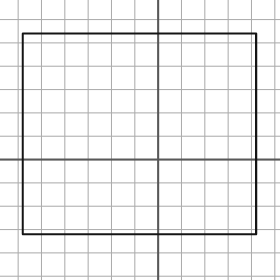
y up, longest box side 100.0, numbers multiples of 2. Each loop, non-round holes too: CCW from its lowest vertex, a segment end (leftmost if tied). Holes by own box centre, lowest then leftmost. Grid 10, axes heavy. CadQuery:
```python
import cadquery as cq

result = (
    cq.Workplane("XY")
    .moveTo(-58.0, -32.0)
    .lineTo(42.0, -32.0)
    .lineTo(42.0, 54.0)
    .lineTo(-58.0, 54.0)
    .close()
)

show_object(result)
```